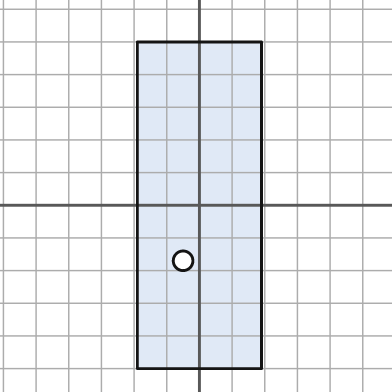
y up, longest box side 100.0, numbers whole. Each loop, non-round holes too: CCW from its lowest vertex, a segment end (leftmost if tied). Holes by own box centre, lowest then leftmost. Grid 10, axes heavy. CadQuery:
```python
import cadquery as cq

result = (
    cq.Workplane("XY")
    .moveTo(-19.0, -50.0)
    .lineTo(19.0, -50.0)
    .lineTo(19.0, 50.0)
    .lineTo(-19.0, 50.0)
    .close()
    .moveTo(-5.0, -17.0)
    .circle(3.0)
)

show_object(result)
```